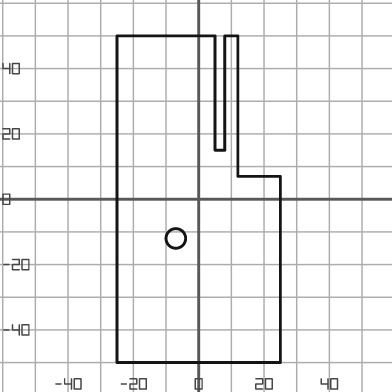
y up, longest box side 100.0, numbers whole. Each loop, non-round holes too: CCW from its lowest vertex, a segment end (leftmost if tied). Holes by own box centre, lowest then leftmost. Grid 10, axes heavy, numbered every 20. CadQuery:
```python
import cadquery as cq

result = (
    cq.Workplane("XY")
    .moveTo(-25.0, -50.0)
    .lineTo(25.0, -50.0)
    .lineTo(25.0, 7.0)
    .lineTo(12.0, 7.0)
    .lineTo(12.0, 50.0)
    .lineTo(8.0, 50.0)
    .lineTo(8.0, 15.0)
    .lineTo(5.0, 15.0)
    .lineTo(5.0, 50.0)
    .lineTo(-25.0, 50.0)
    .close()
    .moveTo(-7.0, -12.0)
    .circle(3.0)
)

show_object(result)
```